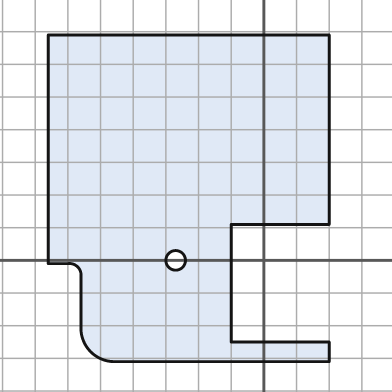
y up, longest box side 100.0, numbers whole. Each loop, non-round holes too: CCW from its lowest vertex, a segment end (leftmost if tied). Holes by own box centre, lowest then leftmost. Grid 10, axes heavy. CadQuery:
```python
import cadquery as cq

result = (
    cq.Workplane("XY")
    .moveTo(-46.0, -31.0)
    .lineTo(20.0, -31.0)
    .lineTo(20.0, -25.0)
    .lineTo(-10.0, -25.0)
    .lineTo(-10.0, 11.0)
    .lineTo(20.0, 11.0)
    .lineTo(20.0, 69.0)
    .lineTo(-66.0, 69.0)
    .lineTo(-66.0, -1.0)
    .lineTo(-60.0, -1.0)
    .threePointArc((-57.0, -2.0), (-56.0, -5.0))
    .lineTo(-56.0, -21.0)
    .threePointArc((-53.0, -28.0), (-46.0, -31.0))
    .close()
    .moveTo(-27.0, 0.0)
    .circle(3.0)
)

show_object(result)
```